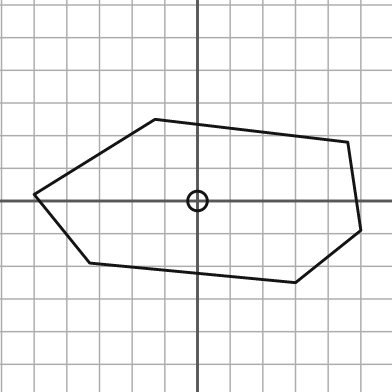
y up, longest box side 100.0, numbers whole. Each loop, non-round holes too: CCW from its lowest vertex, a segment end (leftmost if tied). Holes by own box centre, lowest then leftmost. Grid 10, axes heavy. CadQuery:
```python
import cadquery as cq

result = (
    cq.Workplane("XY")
    .moveTo(30.0, -25.0)
    .lineTo(50.0, -9.0)
    .lineTo(46.0, 18.0)
    .lineTo(-13.0, 25.0)
    .lineTo(-50.0, 2.0)
    .lineTo(-33.0, -19.0)
    .close()
    .moveTo(0.0, 0.0)
    .circle(3.0)
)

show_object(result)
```